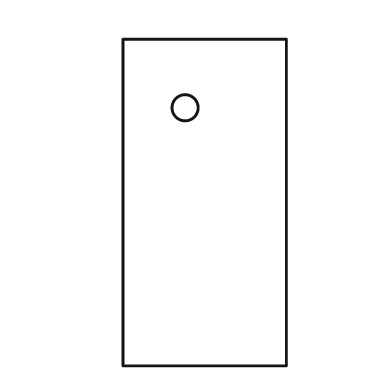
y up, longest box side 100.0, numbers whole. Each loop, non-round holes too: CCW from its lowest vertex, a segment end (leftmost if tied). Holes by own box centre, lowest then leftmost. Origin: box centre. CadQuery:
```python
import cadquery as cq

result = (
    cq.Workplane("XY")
    .moveTo(-25.0, -50.0)
    .lineTo(25.0, -50.0)
    .lineTo(25.0, 50.0)
    .lineTo(-25.0, 50.0)
    .close()
    .moveTo(-6.0, 29.0)
    .circle(4.0)
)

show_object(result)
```